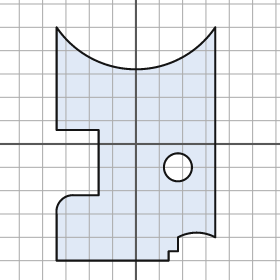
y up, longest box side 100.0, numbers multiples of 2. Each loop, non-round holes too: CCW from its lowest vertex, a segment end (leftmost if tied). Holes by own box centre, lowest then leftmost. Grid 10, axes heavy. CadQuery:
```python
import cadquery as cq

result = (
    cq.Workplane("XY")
    .moveTo(-34.0, -50.0)
    .lineTo(14.0, -50.0)
    .lineTo(14.0, -46.0)
    .lineTo(18.0, -46.0)
    .lineTo(18.0, -40.0)
    .threePointArc((26.0, -38.0), (34.0, -40.0))
    .lineTo(34.0, 50.0)
    .threePointArc((0.0, 32.0), (-34.0, 50.0))
    .lineTo(-34.0, 6.0)
    .lineTo(-16.0, 6.0)
    .lineTo(-16.0, -22.0)
    .lineTo(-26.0, -22.0)
    .threePointArc((-32.0, -24.0), (-34.0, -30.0))
    .close()
    .moveTo(18.0, -10.0)
    .circle(6.0)
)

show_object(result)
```